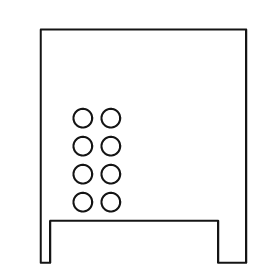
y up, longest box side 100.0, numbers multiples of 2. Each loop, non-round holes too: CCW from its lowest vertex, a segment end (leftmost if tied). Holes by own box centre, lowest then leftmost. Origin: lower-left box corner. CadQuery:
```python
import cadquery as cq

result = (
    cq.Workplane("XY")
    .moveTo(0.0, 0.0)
    .lineTo(4.0, 0.0)
    .lineTo(4.0, 18.0)
    .lineTo(76.0, 18.0)
    .lineTo(76.0, 0.0)
    .lineTo(88.0, 0.0)
    .lineTo(88.0, 100.0)
    .lineTo(0.0, 100.0)
    .close()
    .moveTo(18.0, 26.0)
    .circle(4.0)
    .moveTo(30.0, 26.0)
    .circle(4.0)
    .moveTo(18.0, 38.0)
    .circle(4.0)
    .moveTo(30.0, 38.0)
    .circle(4.0)
    .moveTo(18.0, 50.0)
    .circle(4.0)
    .moveTo(30.0, 50.0)
    .circle(4.0)
    .moveTo(18.0, 62.0)
    .circle(4.0)
    .moveTo(30.0, 62.0)
    .circle(4.0)
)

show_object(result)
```